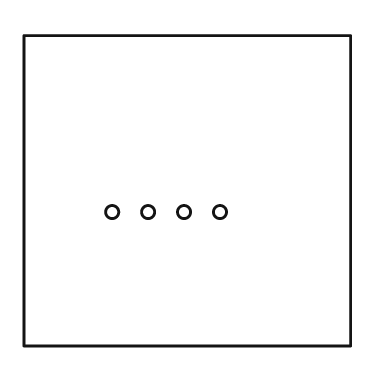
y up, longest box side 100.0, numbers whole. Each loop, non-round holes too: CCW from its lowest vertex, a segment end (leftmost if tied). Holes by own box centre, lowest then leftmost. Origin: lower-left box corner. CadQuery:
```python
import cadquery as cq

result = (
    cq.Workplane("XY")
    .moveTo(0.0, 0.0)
    .lineTo(100.0, 0.0)
    .lineTo(100.0, 95.0)
    .lineTo(0.0, 95.0)
    .close()
    .moveTo(27.0, 41.0)
    .circle(2.0)
    .moveTo(38.0, 41.0)
    .circle(2.0)
    .moveTo(49.0, 41.0)
    .circle(2.0)
    .moveTo(60.0, 41.0)
    .circle(2.0)
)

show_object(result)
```